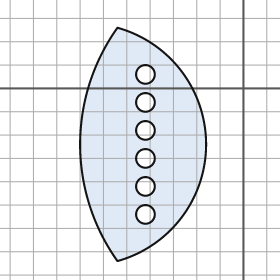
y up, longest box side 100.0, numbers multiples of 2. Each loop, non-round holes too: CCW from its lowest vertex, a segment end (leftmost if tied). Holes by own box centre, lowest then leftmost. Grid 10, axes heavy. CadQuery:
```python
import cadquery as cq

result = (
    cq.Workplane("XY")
    .moveTo(-54.0, -74.0)
    .threePointArc((-16.0, -24.0), (-54.0, 26.0))
    .threePointArc((-70.0, -24.0), (-54.0, -74.0))
    .close()
    .moveTo(-42.0, -54.0)
    .circle(4.0)
    .moveTo(-42.0, -42.0)
    .circle(4.0)
    .moveTo(-42.0, -30.0)
    .circle(4.0)
    .moveTo(-42.0, -18.0)
    .circle(4.0)
    .moveTo(-42.0, -6.0)
    .circle(4.0)
    .moveTo(-42.0, 6.0)
    .circle(4.0)
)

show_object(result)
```